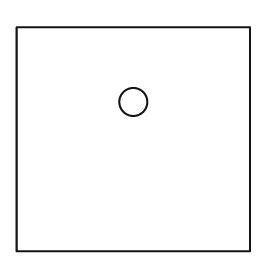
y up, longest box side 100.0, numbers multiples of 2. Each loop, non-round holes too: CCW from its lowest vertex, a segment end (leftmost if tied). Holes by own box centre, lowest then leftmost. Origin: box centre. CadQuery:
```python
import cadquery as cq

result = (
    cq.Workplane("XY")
    .moveTo(-50.0, -48.0)
    .lineTo(50.0, -48.0)
    .lineTo(50.0, 48.0)
    .lineTo(-50.0, 48.0)
    .close()
    .moveTo(0.0, 16.0)
    .circle(6.0)
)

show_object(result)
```